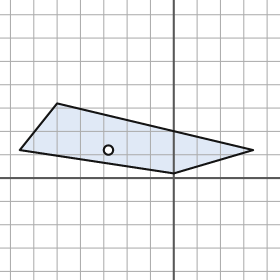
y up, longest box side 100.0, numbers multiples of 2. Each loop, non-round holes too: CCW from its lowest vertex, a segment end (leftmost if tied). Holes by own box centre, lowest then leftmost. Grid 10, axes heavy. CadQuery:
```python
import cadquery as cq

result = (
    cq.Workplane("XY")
    .moveTo(0.0, 2.0)
    .lineTo(34.0, 12.0)
    .lineTo(-50.0, 32.0)
    .lineTo(-66.0, 12.0)
    .close()
    .moveTo(-28.0, 12.0)
    .circle(2.0)
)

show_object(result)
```